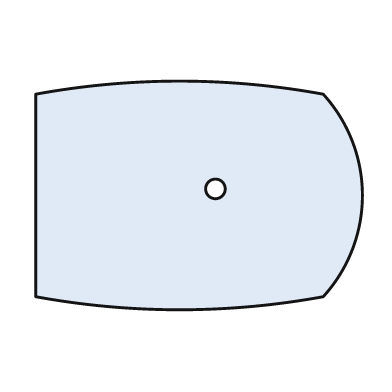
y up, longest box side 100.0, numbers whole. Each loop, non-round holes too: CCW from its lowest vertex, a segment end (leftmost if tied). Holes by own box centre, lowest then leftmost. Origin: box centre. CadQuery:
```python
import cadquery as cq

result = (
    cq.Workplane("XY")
    .moveTo(-50.0, -31.0)
    .threePointArc((-6.0, -35.0), (38.0, -31.0))
    .threePointArc((50.0, 0.0), (38.0, 31.0))
    .threePointArc((-6.0, 35.0), (-50.0, 31.0))
    .close()
    .moveTo(5.0, 2.0)
    .circle(3.0)
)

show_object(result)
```